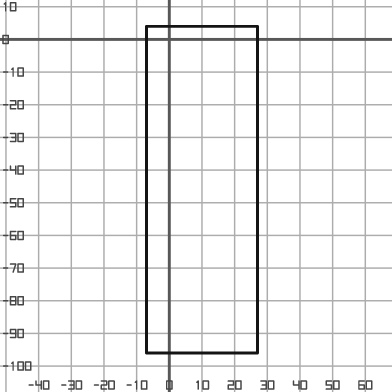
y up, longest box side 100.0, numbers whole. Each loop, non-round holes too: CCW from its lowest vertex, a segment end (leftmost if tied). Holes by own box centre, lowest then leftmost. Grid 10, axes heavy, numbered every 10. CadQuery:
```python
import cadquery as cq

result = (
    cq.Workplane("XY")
    .moveTo(-7.0, -96.0)
    .lineTo(27.0, -96.0)
    .lineTo(27.0, 4.0)
    .lineTo(-7.0, 4.0)
    .close()
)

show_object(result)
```